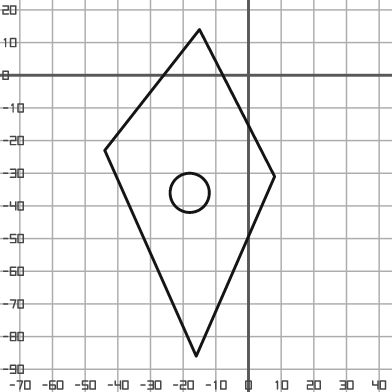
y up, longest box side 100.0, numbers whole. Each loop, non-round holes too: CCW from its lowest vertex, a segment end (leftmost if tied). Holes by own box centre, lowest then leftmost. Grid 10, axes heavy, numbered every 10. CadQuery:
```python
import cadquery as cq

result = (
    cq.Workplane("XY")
    .moveTo(-16.0, -86.0)
    .lineTo(8.0, -31.0)
    .lineTo(-15.0, 14.0)
    .lineTo(-44.0, -23.0)
    .close()
    .moveTo(-18.0, -36.0)
    .circle(6.0)
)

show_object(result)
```